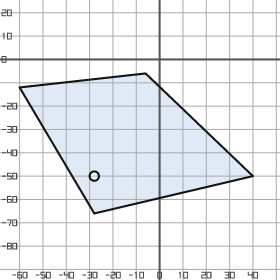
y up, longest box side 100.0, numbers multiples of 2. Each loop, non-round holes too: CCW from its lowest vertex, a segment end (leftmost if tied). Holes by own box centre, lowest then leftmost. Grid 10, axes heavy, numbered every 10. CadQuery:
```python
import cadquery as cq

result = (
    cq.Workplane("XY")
    .moveTo(-28.0, -66.0)
    .lineTo(40.0, -50.0)
    .lineTo(-6.0, -6.0)
    .lineTo(-60.0, -12.0)
    .close()
    .moveTo(-28.0, -50.0)
    .circle(2.0)
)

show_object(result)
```